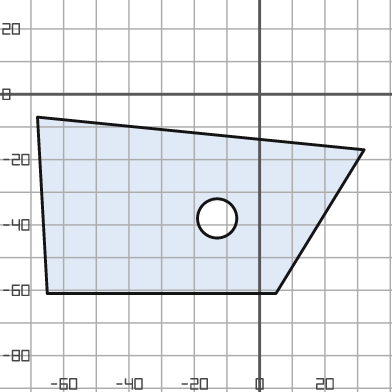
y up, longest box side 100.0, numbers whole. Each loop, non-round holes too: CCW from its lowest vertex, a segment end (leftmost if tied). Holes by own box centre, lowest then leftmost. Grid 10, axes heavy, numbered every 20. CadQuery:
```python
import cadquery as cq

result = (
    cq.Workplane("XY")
    .moveTo(-65.0, -61.0)
    .lineTo(5.0, -61.0)
    .lineTo(32.0, -17.0)
    .lineTo(-68.0, -7.0)
    .close()
    .moveTo(-13.0, -38.0)
    .circle(6.0)
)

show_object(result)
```